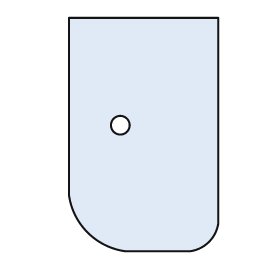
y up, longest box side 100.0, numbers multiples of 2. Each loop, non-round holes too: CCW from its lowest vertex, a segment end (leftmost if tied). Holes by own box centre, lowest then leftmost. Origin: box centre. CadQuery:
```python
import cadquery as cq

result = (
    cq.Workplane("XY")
    .moveTo(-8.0, -50.0)
    .lineTo(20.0, -50.0)
    .threePointArc((28.0, -46.0), (32.0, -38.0))
    .lineTo(32.0, 50.0)
    .lineTo(-32.0, 50.0)
    .lineTo(-32.0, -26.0)
    .threePointArc((-24.0, -42.0), (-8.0, -50.0))
    .close()
    .moveTo(-10.0, 4.0)
    .circle(4.0)
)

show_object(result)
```